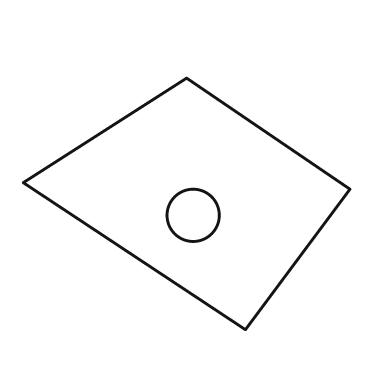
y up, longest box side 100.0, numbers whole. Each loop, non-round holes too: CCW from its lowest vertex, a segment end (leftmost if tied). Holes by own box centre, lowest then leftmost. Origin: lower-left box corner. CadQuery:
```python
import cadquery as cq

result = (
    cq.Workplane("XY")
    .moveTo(68.0, 0.0)
    .lineTo(100.0, 43.0)
    .lineTo(50.0, 77.0)
    .lineTo(0.0, 45.0)
    .close()
    .moveTo(52.0, 35.0)
    .circle(8.0)
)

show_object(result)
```